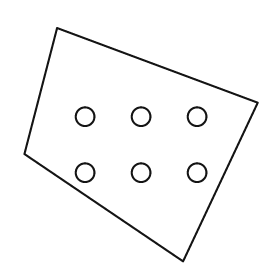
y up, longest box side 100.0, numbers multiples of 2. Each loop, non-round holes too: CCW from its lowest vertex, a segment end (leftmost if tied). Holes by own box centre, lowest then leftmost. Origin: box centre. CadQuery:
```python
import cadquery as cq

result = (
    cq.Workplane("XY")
    .moveTo(18.0, -50.0)
    .lineTo(50.0, 18.0)
    .lineTo(-36.0, 50.0)
    .lineTo(-50.0, -4.0)
    .close()
    .moveTo(-24.0, -12.0)
    .circle(4.0)
    .moveTo(0.0, -12.0)
    .circle(4.0)
    .moveTo(24.0, -12.0)
    .circle(4.0)
    .moveTo(-24.0, 12.0)
    .circle(4.0)
    .moveTo(0.0, 12.0)
    .circle(4.0)
    .moveTo(24.0, 12.0)
    .circle(4.0)
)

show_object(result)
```